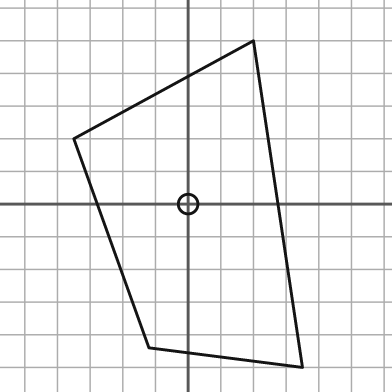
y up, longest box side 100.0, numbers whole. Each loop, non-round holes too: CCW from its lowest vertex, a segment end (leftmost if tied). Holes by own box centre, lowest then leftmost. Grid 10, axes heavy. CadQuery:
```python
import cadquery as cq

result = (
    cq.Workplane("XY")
    .moveTo(35.0, -50.0)
    .lineTo(20.0, 50.0)
    .lineTo(-35.0, 20.0)
    .lineTo(-12.0, -44.0)
    .close()
    .moveTo(0.0, 0.0)
    .circle(3.0)
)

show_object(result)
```